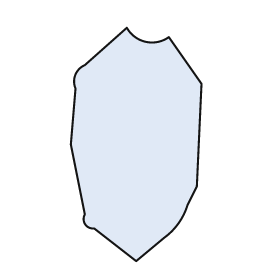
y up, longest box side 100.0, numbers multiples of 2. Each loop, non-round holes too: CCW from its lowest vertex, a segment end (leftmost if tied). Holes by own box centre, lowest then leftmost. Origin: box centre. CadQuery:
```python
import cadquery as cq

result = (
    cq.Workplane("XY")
    .moveTo(0.0, -50.0)
    .lineTo(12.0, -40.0)
    .threePointArc((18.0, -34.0), (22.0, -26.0))
    .lineTo(26.0, -18.0)
    .lineTo(28.0, 26.0)
    .lineTo(14.0, 46.0)
    .threePointArc((4.0, 44.0), (-4.0, 50.0))
    .lineTo(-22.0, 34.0)
    .threePointArc((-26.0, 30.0), (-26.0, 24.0))
    .lineTo(-28.0, 0.0)
    .lineTo(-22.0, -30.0)
    .threePointArc((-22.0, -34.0), (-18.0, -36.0))
    .close()
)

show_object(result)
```